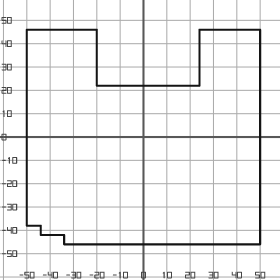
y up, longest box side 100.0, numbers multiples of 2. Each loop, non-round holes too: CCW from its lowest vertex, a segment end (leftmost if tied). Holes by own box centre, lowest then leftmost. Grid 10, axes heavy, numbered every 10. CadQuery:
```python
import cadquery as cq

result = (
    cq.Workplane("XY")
    .moveTo(-34.0, -46.0)
    .lineTo(50.0, -46.0)
    .lineTo(50.0, 46.0)
    .lineTo(24.0, 46.0)
    .lineTo(24.0, 22.0)
    .lineTo(-20.0, 22.0)
    .lineTo(-20.0, 46.0)
    .lineTo(-50.0, 46.0)
    .lineTo(-50.0, -38.0)
    .lineTo(-44.0, -38.0)
    .lineTo(-44.0, -42.0)
    .lineTo(-34.0, -42.0)
    .close()
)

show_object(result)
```